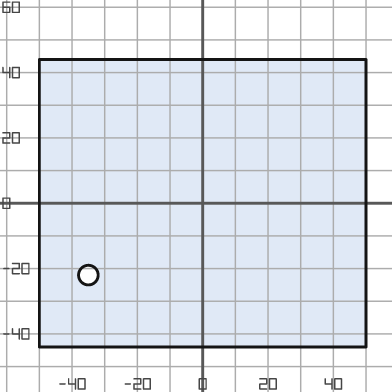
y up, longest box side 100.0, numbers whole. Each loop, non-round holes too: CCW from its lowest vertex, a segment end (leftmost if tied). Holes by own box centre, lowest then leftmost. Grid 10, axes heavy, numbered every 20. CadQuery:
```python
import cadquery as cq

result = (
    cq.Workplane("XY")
    .moveTo(-50.0, -44.0)
    .lineTo(50.0, -44.0)
    .lineTo(50.0, 44.0)
    .lineTo(-50.0, 44.0)
    .close()
    .moveTo(-35.0, -22.0)
    .circle(3.0)
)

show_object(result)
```